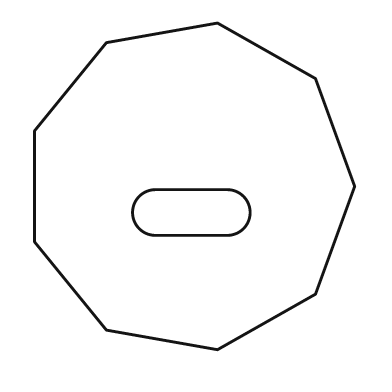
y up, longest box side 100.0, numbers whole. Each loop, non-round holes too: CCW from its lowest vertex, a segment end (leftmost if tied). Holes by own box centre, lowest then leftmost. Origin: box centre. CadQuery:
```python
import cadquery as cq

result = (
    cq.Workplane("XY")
    .moveTo(7.0, -50.0)
    .lineTo(37.0, -33.0)
    .lineTo(49.0, 0.0)
    .lineTo(37.0, 33.0)
    .lineTo(7.0, 50.0)
    .lineTo(-27.0, 44.0)
    .lineTo(-49.0, 17.0)
    .lineTo(-49.0, -17.0)
    .lineTo(-27.0, -44.0)
    .close()
    .moveTo(-12.0, -15.0)
    .lineTo(10.0, -15.0)
    .threePointArc((17.0, -8.0), (10.0, -1.0))
    .lineTo(-12.0, -1.0)
    .threePointArc((-19.0, -8.0), (-12.0, -15.0))
    .close()
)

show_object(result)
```